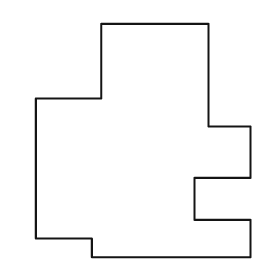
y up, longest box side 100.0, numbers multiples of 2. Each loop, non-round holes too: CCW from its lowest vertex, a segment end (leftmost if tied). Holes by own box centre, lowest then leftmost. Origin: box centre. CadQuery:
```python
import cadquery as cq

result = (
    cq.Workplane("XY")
    .moveTo(-22.0, -50.0)
    .lineTo(46.0, -50.0)
    .lineTo(46.0, -34.0)
    .lineTo(22.0, -34.0)
    .lineTo(22.0, -16.0)
    .lineTo(46.0, -16.0)
    .lineTo(46.0, 6.0)
    .lineTo(28.0, 6.0)
    .lineTo(28.0, 50.0)
    .lineTo(-18.0, 50.0)
    .lineTo(-18.0, 18.0)
    .lineTo(-46.0, 18.0)
    .lineTo(-46.0, -42.0)
    .lineTo(-22.0, -42.0)
    .close()
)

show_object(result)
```